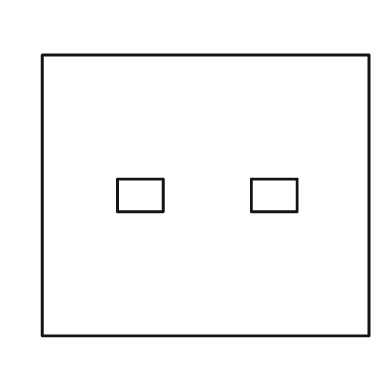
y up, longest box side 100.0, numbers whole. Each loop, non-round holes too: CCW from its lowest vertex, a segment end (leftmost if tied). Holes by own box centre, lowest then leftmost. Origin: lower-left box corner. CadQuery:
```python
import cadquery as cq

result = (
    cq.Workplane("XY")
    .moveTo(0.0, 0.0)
    .lineTo(100.0, 0.0)
    .lineTo(100.0, 86.0)
    .lineTo(0.0, 86.0)
    .close()
    .moveTo(23.0, 38.0)
    .lineTo(37.0, 38.0)
    .lineTo(37.0, 48.0)
    .lineTo(23.0, 48.0)
    .close()
    .moveTo(64.0, 38.0)
    .lineTo(78.0, 38.0)
    .lineTo(78.0, 48.0)
    .lineTo(64.0, 48.0)
    .close()
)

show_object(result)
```